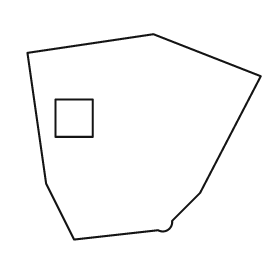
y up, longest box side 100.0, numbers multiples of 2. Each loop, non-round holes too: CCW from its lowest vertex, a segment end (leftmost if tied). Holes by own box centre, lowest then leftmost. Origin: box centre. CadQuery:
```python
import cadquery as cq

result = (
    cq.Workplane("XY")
    .moveTo(-30.0, -44.0)
    .lineTo(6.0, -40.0)
    .threePointArc((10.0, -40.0), (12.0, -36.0))
    .lineTo(24.0, -24.0)
    .lineTo(50.0, 26.0)
    .lineTo(4.0, 44.0)
    .lineTo(-50.0, 36.0)
    .lineTo(-42.0, -20.0)
    .close()
    .moveTo(-38.0, 0.0)
    .lineTo(-22.0, 0.0)
    .lineTo(-22.0, 16.0)
    .lineTo(-38.0, 16.0)
    .close()
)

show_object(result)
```